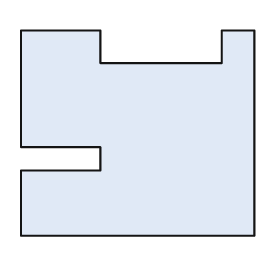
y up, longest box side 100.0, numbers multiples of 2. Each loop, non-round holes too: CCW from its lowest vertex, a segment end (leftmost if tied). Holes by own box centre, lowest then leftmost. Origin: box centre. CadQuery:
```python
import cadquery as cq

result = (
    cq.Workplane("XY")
    .moveTo(-50.0, -44.0)
    .lineTo(50.0, -44.0)
    .lineTo(50.0, 44.0)
    .lineTo(36.0, 44.0)
    .lineTo(36.0, 30.0)
    .lineTo(-16.0, 30.0)
    .lineTo(-16.0, 44.0)
    .lineTo(-50.0, 44.0)
    .lineTo(-50.0, -6.0)
    .lineTo(-16.0, -6.0)
    .lineTo(-16.0, -16.0)
    .lineTo(-50.0, -16.0)
    .close()
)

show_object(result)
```